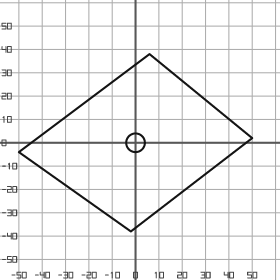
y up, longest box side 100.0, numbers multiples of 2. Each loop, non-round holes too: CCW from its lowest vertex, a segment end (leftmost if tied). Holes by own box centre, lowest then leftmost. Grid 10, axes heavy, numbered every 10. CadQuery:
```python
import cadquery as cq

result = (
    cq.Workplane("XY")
    .moveTo(-2.0, -38.0)
    .lineTo(50.0, 2.0)
    .lineTo(6.0, 38.0)
    .lineTo(-50.0, -4.0)
    .close()
    .moveTo(0.0, 0.0)
    .circle(4.0)
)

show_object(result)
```